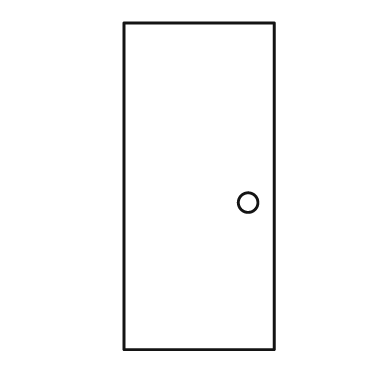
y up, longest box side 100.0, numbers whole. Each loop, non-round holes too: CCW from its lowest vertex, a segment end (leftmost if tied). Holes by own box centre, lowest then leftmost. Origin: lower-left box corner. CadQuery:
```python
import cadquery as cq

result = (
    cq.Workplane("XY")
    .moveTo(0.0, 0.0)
    .lineTo(46.0, 0.0)
    .lineTo(46.0, 100.0)
    .lineTo(0.0, 100.0)
    .close()
    .moveTo(38.0, 45.0)
    .circle(3.0)
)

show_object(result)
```